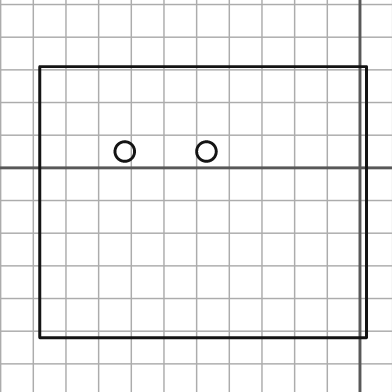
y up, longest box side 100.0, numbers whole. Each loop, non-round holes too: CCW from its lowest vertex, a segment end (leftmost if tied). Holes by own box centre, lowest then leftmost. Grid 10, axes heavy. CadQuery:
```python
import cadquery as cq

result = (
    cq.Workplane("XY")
    .moveTo(-98.0, -52.0)
    .lineTo(2.0, -52.0)
    .lineTo(2.0, 31.0)
    .lineTo(-98.0, 31.0)
    .close()
    .moveTo(-72.0, 5.0)
    .circle(3.0)
    .moveTo(-47.0, 5.0)
    .circle(3.0)
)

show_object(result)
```